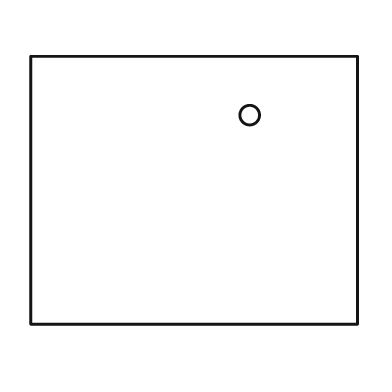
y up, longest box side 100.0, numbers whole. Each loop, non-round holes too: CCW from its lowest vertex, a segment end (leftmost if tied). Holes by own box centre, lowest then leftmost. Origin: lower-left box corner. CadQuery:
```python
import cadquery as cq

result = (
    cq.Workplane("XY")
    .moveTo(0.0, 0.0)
    .lineTo(100.0, 0.0)
    .lineTo(100.0, 82.0)
    .lineTo(0.0, 82.0)
    .close()
    .moveTo(67.0, 64.0)
    .circle(3.0)
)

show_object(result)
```